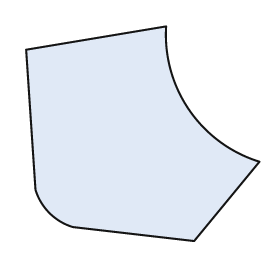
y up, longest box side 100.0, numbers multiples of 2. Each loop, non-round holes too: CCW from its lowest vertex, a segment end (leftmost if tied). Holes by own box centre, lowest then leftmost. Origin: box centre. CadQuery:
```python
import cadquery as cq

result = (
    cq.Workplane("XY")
    .moveTo(22.0, -46.0)
    .lineTo(50.0, -12.0)
    .threePointArc((20.0, 10.0), (10.0, 46.0))
    .lineTo(-50.0, 36.0)
    .lineTo(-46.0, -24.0)
    .threePointArc((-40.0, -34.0), (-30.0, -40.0))
    .close()
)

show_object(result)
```